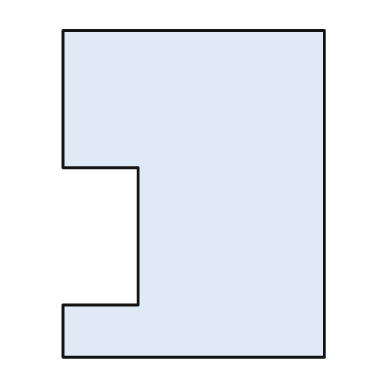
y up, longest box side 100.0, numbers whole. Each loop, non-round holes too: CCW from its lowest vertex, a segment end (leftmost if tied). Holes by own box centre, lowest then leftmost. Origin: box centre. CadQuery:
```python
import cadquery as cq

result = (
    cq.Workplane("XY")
    .moveTo(-40.0, -50.0)
    .lineTo(40.0, -50.0)
    .lineTo(40.0, 50.0)
    .lineTo(-40.0, 50.0)
    .lineTo(-40.0, 8.0)
    .lineTo(-17.0, 8.0)
    .lineTo(-17.0, -34.0)
    .lineTo(-40.0, -34.0)
    .close()
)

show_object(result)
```